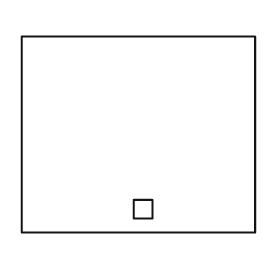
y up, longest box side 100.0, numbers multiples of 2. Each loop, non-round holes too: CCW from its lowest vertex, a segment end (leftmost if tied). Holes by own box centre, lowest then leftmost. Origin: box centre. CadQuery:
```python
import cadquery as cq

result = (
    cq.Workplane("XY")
    .moveTo(-50.0, -42.0)
    .lineTo(50.0, -42.0)
    .lineTo(50.0, 42.0)
    .lineTo(-50.0, 42.0)
    .close()
    .moveTo(-2.0, -36.0)
    .lineTo(6.0, -36.0)
    .lineTo(6.0, -28.0)
    .lineTo(-2.0, -28.0)
    .close()
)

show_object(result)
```